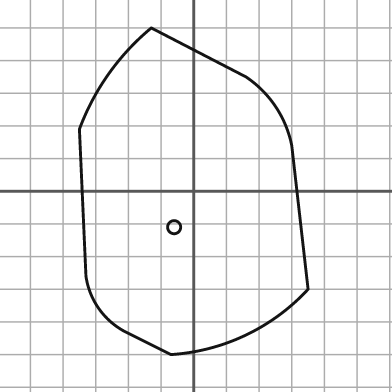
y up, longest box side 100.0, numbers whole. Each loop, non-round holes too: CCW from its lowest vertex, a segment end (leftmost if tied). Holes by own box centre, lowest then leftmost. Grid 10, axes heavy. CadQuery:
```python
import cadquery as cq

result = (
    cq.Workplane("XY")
    .moveTo(-7.0, -50.0)
    .threePointArc((16.0, -44.0), (35.0, -30.0))
    .lineTo(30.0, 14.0)
    .threePointArc((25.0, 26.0), (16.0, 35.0))
    .lineTo(-13.0, 50.0)
    .threePointArc((-26.0, 36.0), (-35.0, 19.0))
    .lineTo(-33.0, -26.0)
    .threePointArc((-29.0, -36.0), (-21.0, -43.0))
    .close()
    .moveTo(-6.0, -11.0)
    .circle(2.0)
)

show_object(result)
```